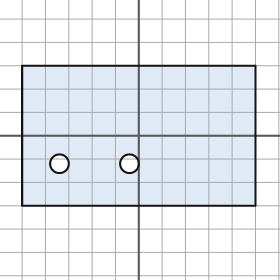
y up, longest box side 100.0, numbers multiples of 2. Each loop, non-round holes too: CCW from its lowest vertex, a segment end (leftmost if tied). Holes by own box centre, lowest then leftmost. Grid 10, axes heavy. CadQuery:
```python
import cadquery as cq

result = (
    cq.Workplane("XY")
    .moveTo(-50.0, -30.0)
    .lineTo(50.0, -30.0)
    .lineTo(50.0, 30.0)
    .lineTo(-50.0, 30.0)
    .close()
    .moveTo(-34.0, -12.0)
    .circle(4.0)
    .moveTo(-4.0, -12.0)
    .circle(4.0)
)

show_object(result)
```